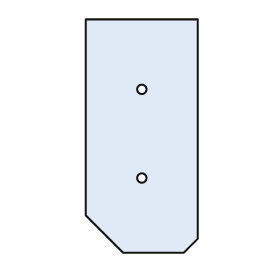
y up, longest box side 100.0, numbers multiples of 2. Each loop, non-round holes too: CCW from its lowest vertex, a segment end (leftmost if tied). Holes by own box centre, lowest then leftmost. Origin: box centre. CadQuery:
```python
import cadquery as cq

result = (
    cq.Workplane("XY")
    .moveTo(-8.0, -50.0)
    .lineTo(18.0, -50.0)
    .lineTo(24.0, -44.0)
    .lineTo(24.0, 50.0)
    .lineTo(-24.0, 50.0)
    .lineTo(-24.0, -34.0)
    .close()
    .moveTo(0.0, -18.0)
    .circle(2.0)
    .moveTo(0.0, 20.0)
    .circle(2.0)
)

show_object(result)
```